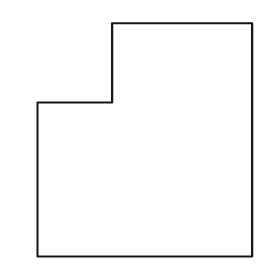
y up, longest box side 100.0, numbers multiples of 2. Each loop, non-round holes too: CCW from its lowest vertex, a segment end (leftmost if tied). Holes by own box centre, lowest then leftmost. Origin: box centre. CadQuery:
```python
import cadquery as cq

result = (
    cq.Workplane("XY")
    .moveTo(-46.0, -50.0)
    .lineTo(46.0, -50.0)
    .lineTo(46.0, 50.0)
    .lineTo(-14.0, 50.0)
    .lineTo(-14.0, 16.0)
    .lineTo(-46.0, 16.0)
    .close()
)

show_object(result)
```